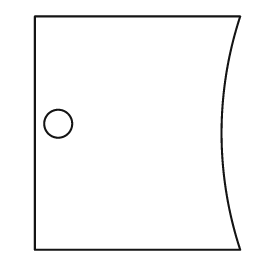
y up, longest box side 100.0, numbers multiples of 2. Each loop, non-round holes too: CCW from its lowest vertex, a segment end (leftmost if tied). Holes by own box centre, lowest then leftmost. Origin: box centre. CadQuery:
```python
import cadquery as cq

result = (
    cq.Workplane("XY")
    .moveTo(-44.0, -50.0)
    .lineTo(44.0, -50.0)
    .threePointArc((36.0, 0.0), (44.0, 50.0))
    .lineTo(-44.0, 50.0)
    .close()
    .moveTo(-34.0, 4.0)
    .circle(6.0)
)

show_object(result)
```